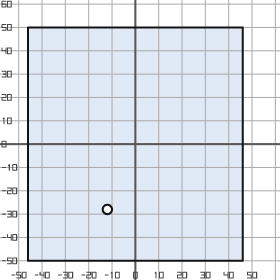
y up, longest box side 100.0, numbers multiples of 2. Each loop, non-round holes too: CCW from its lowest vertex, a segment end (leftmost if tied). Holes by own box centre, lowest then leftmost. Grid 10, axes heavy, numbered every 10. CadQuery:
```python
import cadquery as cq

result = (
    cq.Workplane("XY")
    .moveTo(-46.0, -50.0)
    .lineTo(46.0, -50.0)
    .lineTo(46.0, 50.0)
    .lineTo(-46.0, 50.0)
    .close()
    .moveTo(-12.0, -28.0)
    .circle(2.0)
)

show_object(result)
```